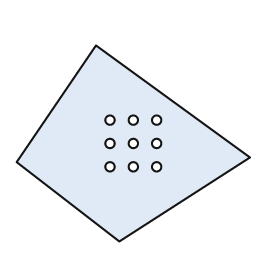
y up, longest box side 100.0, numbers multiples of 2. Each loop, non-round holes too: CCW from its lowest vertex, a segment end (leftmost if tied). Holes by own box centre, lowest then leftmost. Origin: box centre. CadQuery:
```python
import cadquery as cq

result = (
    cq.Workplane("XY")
    .moveTo(-6.0, -42.0)
    .lineTo(50.0, -6.0)
    .lineTo(-16.0, 42.0)
    .lineTo(-50.0, -8.0)
    .close()
    .moveTo(-10.0, -10.0)
    .circle(2.0)
    .moveTo(0.0, -10.0)
    .circle(2.0)
    .moveTo(10.0, -10.0)
    .circle(2.0)
    .moveTo(-10.0, 0.0)
    .circle(2.0)
    .moveTo(0.0, 0.0)
    .circle(2.0)
    .moveTo(10.0, 0.0)
    .circle(2.0)
    .moveTo(-10.0, 10.0)
    .circle(2.0)
    .moveTo(0.0, 10.0)
    .circle(2.0)
    .moveTo(10.0, 10.0)
    .circle(2.0)
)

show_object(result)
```